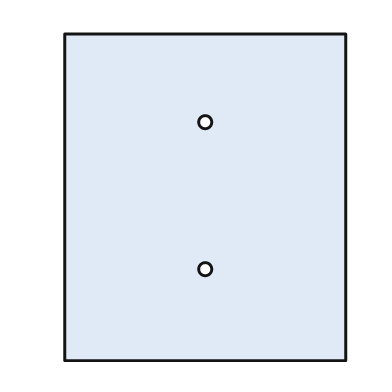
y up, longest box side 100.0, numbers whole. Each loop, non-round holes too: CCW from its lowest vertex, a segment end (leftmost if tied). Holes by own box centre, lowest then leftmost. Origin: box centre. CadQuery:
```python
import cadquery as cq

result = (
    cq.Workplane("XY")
    .moveTo(-43.0, -50.0)
    .lineTo(43.0, -50.0)
    .lineTo(43.0, 50.0)
    .lineTo(-43.0, 50.0)
    .close()
    .moveTo(0.0, -22.0)
    .circle(2.0)
    .moveTo(0.0, 23.0)
    .circle(2.0)
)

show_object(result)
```